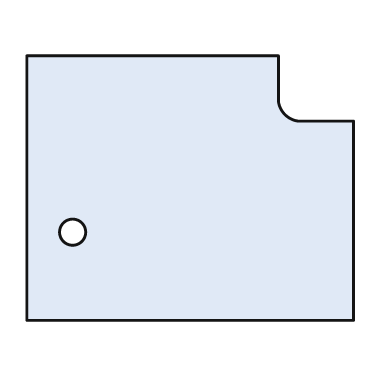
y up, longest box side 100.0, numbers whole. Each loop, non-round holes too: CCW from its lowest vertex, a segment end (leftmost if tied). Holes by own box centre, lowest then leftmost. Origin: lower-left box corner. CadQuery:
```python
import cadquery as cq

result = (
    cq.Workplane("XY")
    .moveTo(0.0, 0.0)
    .lineTo(100.0, 0.0)
    .lineTo(100.0, 61.0)
    .lineTo(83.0, 61.0)
    .threePointArc((79.0, 63.0), (77.0, 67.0))
    .lineTo(77.0, 81.0)
    .lineTo(0.0, 81.0)
    .close()
    .moveTo(14.0, 27.0)
    .circle(4.0)
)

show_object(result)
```